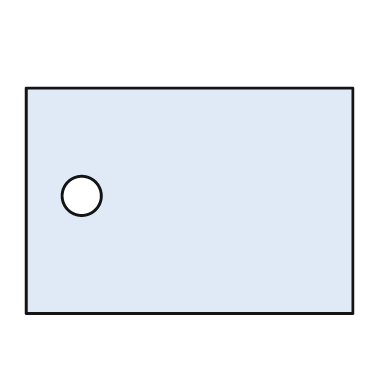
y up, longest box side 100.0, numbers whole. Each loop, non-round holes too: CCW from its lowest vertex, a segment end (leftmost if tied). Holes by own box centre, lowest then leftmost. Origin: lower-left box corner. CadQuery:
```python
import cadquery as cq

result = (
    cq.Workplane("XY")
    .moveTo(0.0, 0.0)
    .lineTo(100.0, 0.0)
    .lineTo(100.0, 69.0)
    .lineTo(0.0, 69.0)
    .close()
    .moveTo(17.0, 36.0)
    .circle(6.0)
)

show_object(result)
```